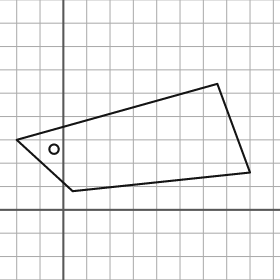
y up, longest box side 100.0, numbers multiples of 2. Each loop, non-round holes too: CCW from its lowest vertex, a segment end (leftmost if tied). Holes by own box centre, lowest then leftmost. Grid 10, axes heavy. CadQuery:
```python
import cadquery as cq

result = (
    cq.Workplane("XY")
    .moveTo(4.0, 8.0)
    .lineTo(80.0, 16.0)
    .lineTo(66.0, 54.0)
    .lineTo(-20.0, 30.0)
    .close()
    .moveTo(-4.0, 26.0)
    .circle(2.0)
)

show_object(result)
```